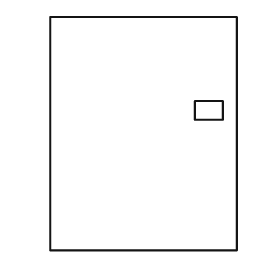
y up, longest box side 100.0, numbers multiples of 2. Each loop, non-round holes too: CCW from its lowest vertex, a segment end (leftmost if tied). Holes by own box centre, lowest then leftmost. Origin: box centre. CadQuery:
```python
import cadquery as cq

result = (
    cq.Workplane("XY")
    .moveTo(-40.0, -50.0)
    .lineTo(40.0, -50.0)
    .lineTo(40.0, 50.0)
    .lineTo(-40.0, 50.0)
    .close()
    .moveTo(22.0, 6.0)
    .lineTo(34.0, 6.0)
    .lineTo(34.0, 14.0)
    .lineTo(22.0, 14.0)
    .close()
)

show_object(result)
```